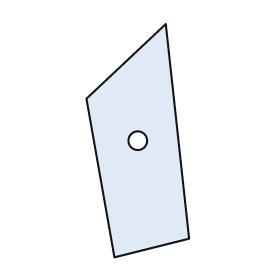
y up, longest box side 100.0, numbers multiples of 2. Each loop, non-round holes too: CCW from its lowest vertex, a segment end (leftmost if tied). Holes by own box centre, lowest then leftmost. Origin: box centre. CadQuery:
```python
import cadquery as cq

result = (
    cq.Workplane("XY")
    .moveTo(-10.0, -50.0)
    .lineTo(22.0, -42.0)
    .lineTo(12.0, 50.0)
    .lineTo(-22.0, 18.0)
    .close()
    .moveTo(0.0, 0.0)
    .circle(4.0)
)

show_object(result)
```